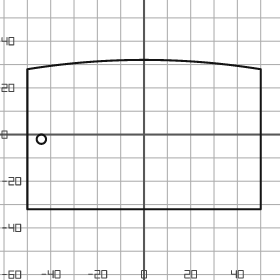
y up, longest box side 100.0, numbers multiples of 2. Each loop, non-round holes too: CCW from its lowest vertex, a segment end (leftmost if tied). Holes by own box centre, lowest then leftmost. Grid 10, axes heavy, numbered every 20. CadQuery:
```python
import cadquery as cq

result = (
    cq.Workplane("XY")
    .moveTo(-50.0, -32.0)
    .lineTo(50.0, -32.0)
    .lineTo(50.0, 28.0)
    .threePointArc((0.0, 32.0), (-50.0, 28.0))
    .close()
    .moveTo(-44.0, -2.0)
    .circle(2.0)
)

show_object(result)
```